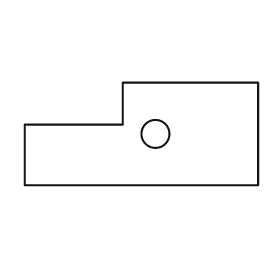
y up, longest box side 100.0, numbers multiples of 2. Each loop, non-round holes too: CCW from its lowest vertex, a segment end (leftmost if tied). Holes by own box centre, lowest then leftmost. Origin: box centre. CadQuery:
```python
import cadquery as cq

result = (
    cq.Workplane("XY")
    .moveTo(-50.0, -22.0)
    .lineTo(50.0, -22.0)
    .lineTo(50.0, 22.0)
    .lineTo(-8.0, 22.0)
    .lineTo(-8.0, 4.0)
    .lineTo(-50.0, 4.0)
    .close()
    .moveTo(6.0, 0.0)
    .circle(6.0)
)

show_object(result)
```